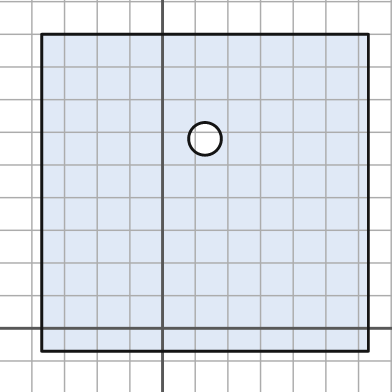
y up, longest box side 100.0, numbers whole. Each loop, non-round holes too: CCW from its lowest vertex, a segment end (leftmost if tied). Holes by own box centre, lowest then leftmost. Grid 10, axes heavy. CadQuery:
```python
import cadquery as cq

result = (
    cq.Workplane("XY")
    .moveTo(-37.0, -7.0)
    .lineTo(63.0, -7.0)
    .lineTo(63.0, 90.0)
    .lineTo(-37.0, 90.0)
    .close()
    .moveTo(13.0, 58.0)
    .circle(5.0)
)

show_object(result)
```